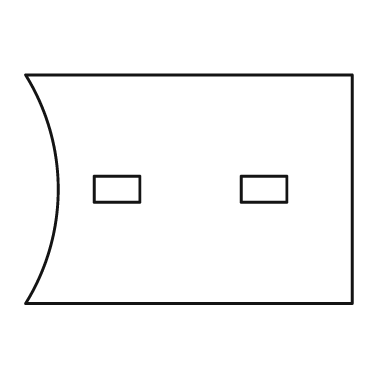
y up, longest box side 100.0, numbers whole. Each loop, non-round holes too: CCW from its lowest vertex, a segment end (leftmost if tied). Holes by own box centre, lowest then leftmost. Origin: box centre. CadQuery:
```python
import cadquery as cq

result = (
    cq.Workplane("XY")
    .moveTo(-50.0, -35.0)
    .lineTo(50.0, -35.0)
    .lineTo(50.0, 35.0)
    .lineTo(-50.0, 35.0)
    .threePointArc((-40.0, 0.0), (-50.0, -35.0))
    .close()
    .moveTo(-29.0, -4.0)
    .lineTo(-15.0, -4.0)
    .lineTo(-15.0, 4.0)
    .lineTo(-29.0, 4.0)
    .close()
    .moveTo(16.0, -4.0)
    .lineTo(30.0, -4.0)
    .lineTo(30.0, 4.0)
    .lineTo(16.0, 4.0)
    .close()
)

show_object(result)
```